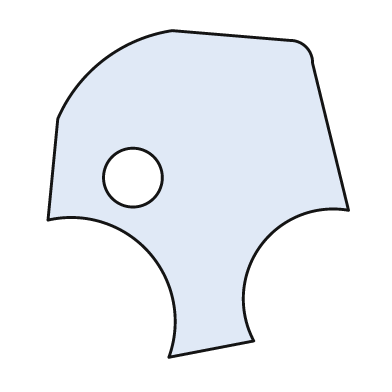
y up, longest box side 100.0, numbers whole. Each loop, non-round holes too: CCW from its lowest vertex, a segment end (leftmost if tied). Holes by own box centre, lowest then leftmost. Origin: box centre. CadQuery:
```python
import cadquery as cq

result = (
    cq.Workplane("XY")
    .moveTo(-9.0, -50.0)
    .lineTo(17.0, -45.0)
    .threePointArc((19.0, -16.0), (46.0, -5.0))
    .lineTo(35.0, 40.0)
    .threePointArc((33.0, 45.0), (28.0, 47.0))
    .lineTo(-8.0, 50.0)
    .threePointArc((-29.0, 41.0), (-43.0, 23.0))
    .lineTo(-46.0, -8.0)
    .threePointArc((-15.0, -18.0), (-9.0, -50.0))
    .close()
    .moveTo(-20.0, 5.0)
    .circle(9.0)
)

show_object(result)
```